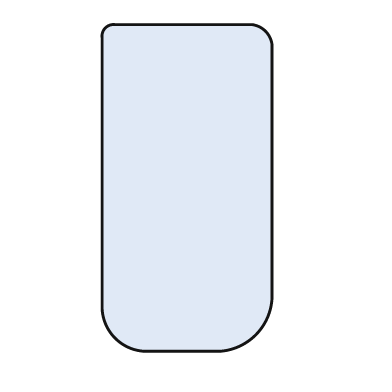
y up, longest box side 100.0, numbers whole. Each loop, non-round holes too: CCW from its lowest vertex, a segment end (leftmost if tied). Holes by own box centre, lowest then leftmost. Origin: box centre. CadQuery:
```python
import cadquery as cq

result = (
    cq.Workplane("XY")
    .moveTo(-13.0, -50.0)
    .lineTo(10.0, -50.0)
    .threePointArc((21.0, -45.0), (26.0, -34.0))
    .lineTo(26.0, 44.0)
    .threePointArc((24.0, 48.0), (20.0, 50.0))
    .lineTo(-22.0, 50.0)
    .threePointArc((-25.0, 49.0), (-26.0, 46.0))
    .lineTo(-26.0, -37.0)
    .threePointArc((-22.0, -46.0), (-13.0, -50.0))
    .close()
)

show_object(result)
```